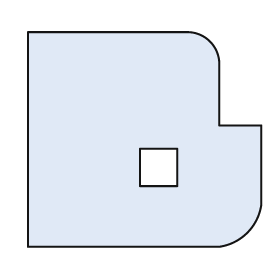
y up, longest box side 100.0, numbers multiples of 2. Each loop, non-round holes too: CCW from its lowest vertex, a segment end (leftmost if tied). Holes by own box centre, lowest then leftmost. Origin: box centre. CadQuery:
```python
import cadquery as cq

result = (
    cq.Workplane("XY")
    .moveTo(-50.0, -46.0)
    .lineTo(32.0, -46.0)
    .threePointArc((44.0, -40.0), (50.0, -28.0))
    .lineTo(50.0, 6.0)
    .lineTo(32.0, 6.0)
    .lineTo(32.0, 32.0)
    .threePointArc((28.0, 42.0), (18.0, 46.0))
    .lineTo(-50.0, 46.0)
    .close()
    .moveTo(-2.0, -20.0)
    .lineTo(14.0, -20.0)
    .lineTo(14.0, -4.0)
    .lineTo(-2.0, -4.0)
    .close()
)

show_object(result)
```